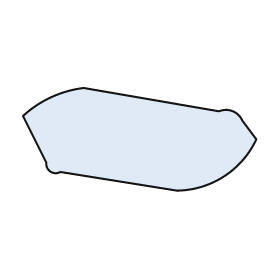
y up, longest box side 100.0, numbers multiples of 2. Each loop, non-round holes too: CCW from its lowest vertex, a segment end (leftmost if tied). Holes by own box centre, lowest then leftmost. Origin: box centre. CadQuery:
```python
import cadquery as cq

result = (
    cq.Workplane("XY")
    .moveTo(16.0, -22.0)
    .threePointArc((36.0, -16.0), (50.0, 0.0))
    .lineTo(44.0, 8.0)
    .threePointArc((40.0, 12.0), (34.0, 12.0))
    .lineTo(-24.0, 22.0)
    .threePointArc((-38.0, 18.0), (-50.0, 10.0))
    .lineTo(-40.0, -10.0)
    .threePointArc((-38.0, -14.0), (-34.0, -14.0))
    .close()
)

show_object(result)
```